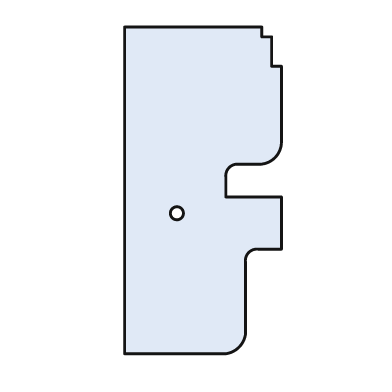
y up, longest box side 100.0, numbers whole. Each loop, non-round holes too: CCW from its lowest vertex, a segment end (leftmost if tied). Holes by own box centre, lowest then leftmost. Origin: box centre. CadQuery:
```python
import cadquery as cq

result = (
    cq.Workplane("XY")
    .moveTo(-24.0, -50.0)
    .lineTo(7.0, -50.0)
    .threePointArc((11.0, -48.0), (13.0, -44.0))
    .lineTo(13.0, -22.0)
    .threePointArc((14.0, -19.0), (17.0, -18.0))
    .lineTo(24.0, -18.0)
    .lineTo(24.0, -2.0)
    .lineTo(7.0, -2.0)
    .lineTo(7.0, 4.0)
    .threePointArc((8.0, 7.0), (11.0, 8.0))
    .lineTo(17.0, 8.0)
    .threePointArc((22.0, 10.0), (24.0, 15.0))
    .lineTo(24.0, 38.0)
    .lineTo(21.0, 38.0)
    .lineTo(21.0, 47.0)
    .lineTo(18.0, 47.0)
    .lineTo(18.0, 50.0)
    .lineTo(-24.0, 50.0)
    .close()
    .moveTo(-8.0, -7.0)
    .circle(2.0)
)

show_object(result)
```